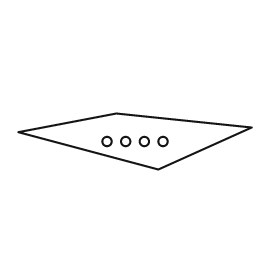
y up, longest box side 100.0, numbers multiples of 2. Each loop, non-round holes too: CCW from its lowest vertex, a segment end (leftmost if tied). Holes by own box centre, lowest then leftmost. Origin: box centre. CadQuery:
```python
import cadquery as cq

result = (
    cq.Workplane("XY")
    .moveTo(10.0, -12.0)
    .lineTo(50.0, 6.0)
    .lineTo(-8.0, 12.0)
    .lineTo(-50.0, 4.0)
    .close()
    .moveTo(-12.0, 0.0)
    .circle(2.0)
    .moveTo(-4.0, 0.0)
    .circle(2.0)
    .moveTo(4.0, 0.0)
    .circle(2.0)
    .moveTo(12.0, 0.0)
    .circle(2.0)
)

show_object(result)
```